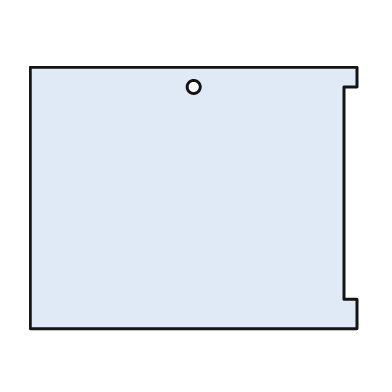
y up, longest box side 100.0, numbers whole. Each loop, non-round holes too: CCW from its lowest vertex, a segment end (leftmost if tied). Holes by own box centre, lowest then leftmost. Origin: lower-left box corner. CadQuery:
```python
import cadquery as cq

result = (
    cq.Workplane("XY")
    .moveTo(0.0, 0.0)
    .lineTo(100.0, 0.0)
    .lineTo(100.0, 9.0)
    .lineTo(96.0, 9.0)
    .lineTo(96.0, 74.0)
    .lineTo(100.0, 74.0)
    .lineTo(100.0, 80.0)
    .lineTo(0.0, 80.0)
    .close()
    .moveTo(50.0, 74.0)
    .circle(2.0)
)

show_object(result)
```